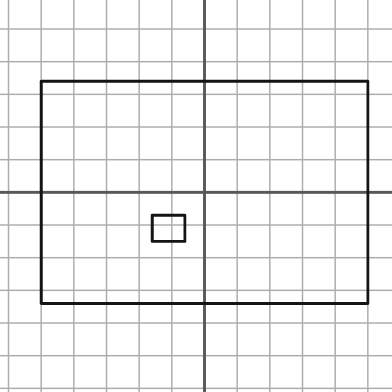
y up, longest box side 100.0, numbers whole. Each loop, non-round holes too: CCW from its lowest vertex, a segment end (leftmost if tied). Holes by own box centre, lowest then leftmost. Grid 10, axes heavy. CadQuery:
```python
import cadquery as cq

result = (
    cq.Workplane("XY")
    .moveTo(-50.0, -34.0)
    .lineTo(50.0, -34.0)
    .lineTo(50.0, 34.0)
    .lineTo(-50.0, 34.0)
    .close()
    .moveTo(-16.0, -15.0)
    .lineTo(-6.0, -15.0)
    .lineTo(-6.0, -7.0)
    .lineTo(-16.0, -7.0)
    .close()
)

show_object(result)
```